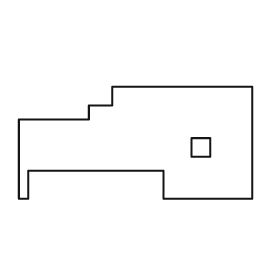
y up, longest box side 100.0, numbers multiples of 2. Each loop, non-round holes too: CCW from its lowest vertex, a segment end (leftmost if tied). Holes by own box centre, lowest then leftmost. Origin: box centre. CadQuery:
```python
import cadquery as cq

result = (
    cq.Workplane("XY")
    .moveTo(-50.0, -24.0)
    .lineTo(-46.0, -24.0)
    .lineTo(-46.0, -12.0)
    .lineTo(12.0, -12.0)
    .lineTo(12.0, -24.0)
    .lineTo(50.0, -24.0)
    .lineTo(50.0, 24.0)
    .lineTo(-10.0, 24.0)
    .lineTo(-10.0, 16.0)
    .lineTo(-20.0, 16.0)
    .lineTo(-20.0, 10.0)
    .lineTo(-50.0, 10.0)
    .close()
    .moveTo(24.0, -6.0)
    .lineTo(32.0, -6.0)
    .lineTo(32.0, 2.0)
    .lineTo(24.0, 2.0)
    .close()
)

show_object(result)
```